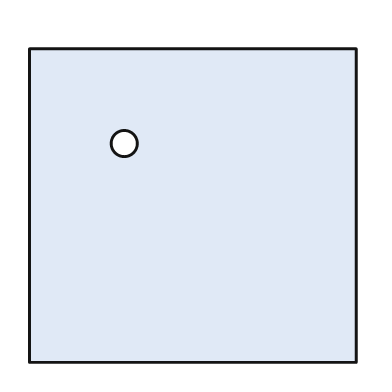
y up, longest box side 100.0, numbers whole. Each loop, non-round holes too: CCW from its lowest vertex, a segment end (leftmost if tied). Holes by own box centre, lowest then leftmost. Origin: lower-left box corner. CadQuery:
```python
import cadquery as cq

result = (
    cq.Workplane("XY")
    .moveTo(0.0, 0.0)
    .lineTo(100.0, 0.0)
    .lineTo(100.0, 96.0)
    .lineTo(0.0, 96.0)
    .close()
    .moveTo(29.0, 67.0)
    .circle(4.0)
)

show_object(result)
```